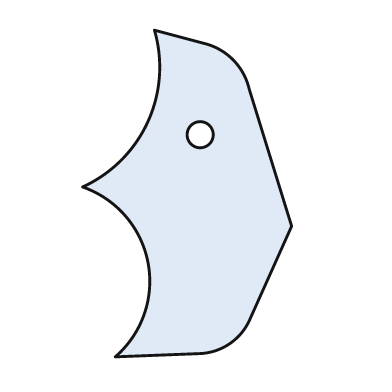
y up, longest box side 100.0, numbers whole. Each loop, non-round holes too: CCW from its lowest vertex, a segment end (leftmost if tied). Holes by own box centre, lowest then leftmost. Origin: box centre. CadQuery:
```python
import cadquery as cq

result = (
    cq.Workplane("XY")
    .moveTo(-22.0, -50.0)
    .lineTo(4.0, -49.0)
    .threePointArc((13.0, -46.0), (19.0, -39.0))
    .lineTo(32.0, -10.0)
    .lineTo(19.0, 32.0)
    .threePointArc((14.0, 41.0), (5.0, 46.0))
    .lineTo(-10.0, 50.0)
    .threePointArc((-12.0, 22.0), (-32.0, 2.0))
    .threePointArc((-12.0, -21.0), (-22.0, -50.0))
    .close()
    .moveTo(4.0, 18.0)
    .circle(4.0)
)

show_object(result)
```